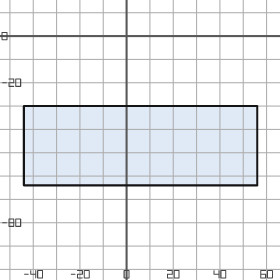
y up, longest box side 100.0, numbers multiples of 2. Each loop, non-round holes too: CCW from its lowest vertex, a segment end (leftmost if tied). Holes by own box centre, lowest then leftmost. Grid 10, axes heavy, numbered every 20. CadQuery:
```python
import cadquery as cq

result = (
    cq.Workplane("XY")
    .moveTo(-44.0, -64.0)
    .lineTo(56.0, -64.0)
    .lineTo(56.0, -30.0)
    .lineTo(-44.0, -30.0)
    .close()
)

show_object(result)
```